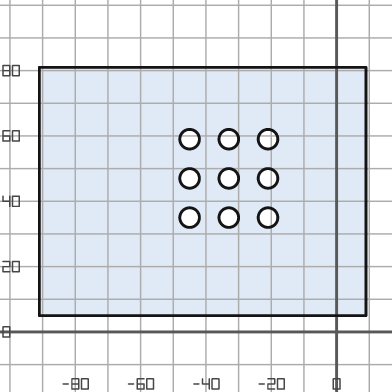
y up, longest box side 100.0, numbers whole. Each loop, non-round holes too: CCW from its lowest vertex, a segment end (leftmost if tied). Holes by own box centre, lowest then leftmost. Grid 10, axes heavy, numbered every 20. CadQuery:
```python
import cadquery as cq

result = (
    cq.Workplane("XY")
    .moveTo(-91.0, 5.0)
    .lineTo(9.0, 5.0)
    .lineTo(9.0, 81.0)
    .lineTo(-91.0, 81.0)
    .close()
    .moveTo(-45.0, 35.0)
    .circle(3.0)
    .moveTo(-33.0, 35.0)
    .circle(3.0)
    .moveTo(-21.0, 35.0)
    .circle(3.0)
    .moveTo(-45.0, 47.0)
    .circle(3.0)
    .moveTo(-33.0, 47.0)
    .circle(3.0)
    .moveTo(-21.0, 47.0)
    .circle(3.0)
    .moveTo(-45.0, 59.0)
    .circle(3.0)
    .moveTo(-33.0, 59.0)
    .circle(3.0)
    .moveTo(-21.0, 59.0)
    .circle(3.0)
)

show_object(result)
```